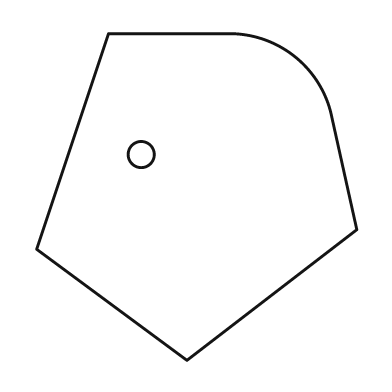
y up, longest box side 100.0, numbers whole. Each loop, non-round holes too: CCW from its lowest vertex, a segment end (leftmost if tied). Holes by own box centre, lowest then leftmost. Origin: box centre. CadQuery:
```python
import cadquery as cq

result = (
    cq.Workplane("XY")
    .moveTo(-3.0, -50.0)
    .lineTo(49.0, -10.0)
    .lineTo(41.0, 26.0)
    .threePointArc((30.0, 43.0), (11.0, 50.0))
    .lineTo(-27.0, 50.0)
    .lineTo(-49.0, -16.0)
    .close()
    .moveTo(-17.0, 13.0)
    .circle(4.0)
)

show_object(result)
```